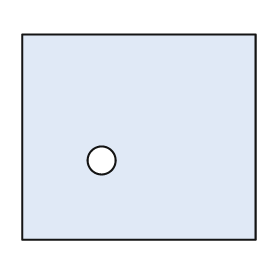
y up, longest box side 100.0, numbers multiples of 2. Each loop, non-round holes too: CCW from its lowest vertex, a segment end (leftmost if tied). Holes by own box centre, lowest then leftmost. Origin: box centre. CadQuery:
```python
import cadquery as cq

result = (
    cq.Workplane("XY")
    .moveTo(-50.0, -44.0)
    .lineTo(50.0, -44.0)
    .lineTo(50.0, 44.0)
    .lineTo(-50.0, 44.0)
    .close()
    .moveTo(-16.0, -10.0)
    .circle(6.0)
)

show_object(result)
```